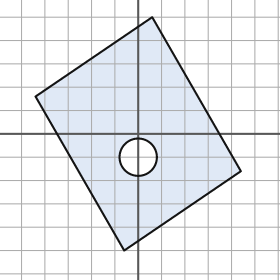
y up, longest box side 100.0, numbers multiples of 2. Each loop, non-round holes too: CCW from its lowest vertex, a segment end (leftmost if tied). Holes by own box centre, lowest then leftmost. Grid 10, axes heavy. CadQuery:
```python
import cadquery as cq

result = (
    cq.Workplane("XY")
    .moveTo(-6.0, -50.0)
    .lineTo(44.0, -16.0)
    .lineTo(6.0, 50.0)
    .lineTo(-44.0, 16.0)
    .close()
    .moveTo(0.0, -10.0)
    .circle(8.0)
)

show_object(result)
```